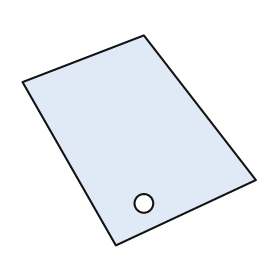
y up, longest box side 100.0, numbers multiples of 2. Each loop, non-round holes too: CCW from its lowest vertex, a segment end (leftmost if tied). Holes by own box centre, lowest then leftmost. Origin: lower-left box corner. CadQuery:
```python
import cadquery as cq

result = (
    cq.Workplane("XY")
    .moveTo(40.0, 0.0)
    .lineTo(100.0, 28.0)
    .lineTo(52.0, 90.0)
    .lineTo(0.0, 70.0)
    .close()
    .moveTo(52.0, 18.0)
    .circle(4.0)
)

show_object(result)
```